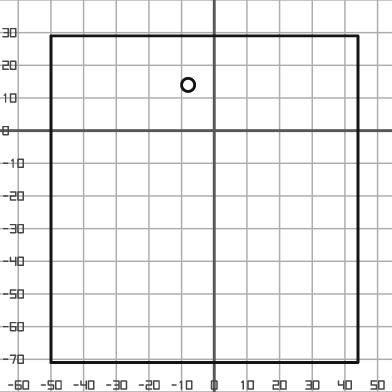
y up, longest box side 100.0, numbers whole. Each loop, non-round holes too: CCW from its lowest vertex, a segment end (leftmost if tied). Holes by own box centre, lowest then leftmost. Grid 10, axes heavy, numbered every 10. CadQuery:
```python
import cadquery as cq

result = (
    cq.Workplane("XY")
    .moveTo(-50.0, -71.0)
    .lineTo(44.0, -71.0)
    .lineTo(44.0, 29.0)
    .lineTo(-50.0, 29.0)
    .close()
    .moveTo(-8.0, 14.0)
    .circle(2.0)
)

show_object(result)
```